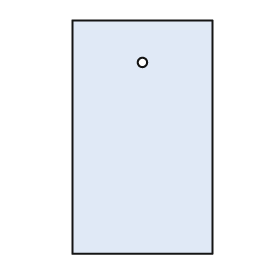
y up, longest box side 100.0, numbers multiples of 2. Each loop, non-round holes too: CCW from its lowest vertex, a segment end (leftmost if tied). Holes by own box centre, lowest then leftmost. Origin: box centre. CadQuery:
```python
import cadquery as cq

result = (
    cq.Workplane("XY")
    .moveTo(-30.0, -50.0)
    .lineTo(30.0, -50.0)
    .lineTo(30.0, 50.0)
    .lineTo(-30.0, 50.0)
    .close()
    .moveTo(0.0, 32.0)
    .circle(2.0)
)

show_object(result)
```